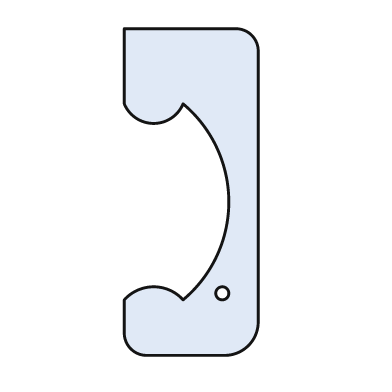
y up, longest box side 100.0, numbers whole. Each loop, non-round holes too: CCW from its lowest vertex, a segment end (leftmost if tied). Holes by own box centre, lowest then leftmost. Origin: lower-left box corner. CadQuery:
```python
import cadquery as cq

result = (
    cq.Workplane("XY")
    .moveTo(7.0, 0.0)
    .lineTo(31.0, 0.0)
    .threePointArc((38.0, 3.0), (41.0, 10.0))
    .lineTo(41.0, 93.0)
    .threePointArc((39.0, 98.0), (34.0, 100.0))
    .lineTo(0.0, 100.0)
    .lineTo(0.0, 77.0)
    .threePointArc((9.0, 71.0), (18.0, 77.0))
    .threePointArc((32.0, 47.0), (18.0, 17.0))
    .threePointArc((9.0, 21.0), (0.0, 17.0))
    .lineTo(0.0, 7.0)
    .threePointArc((2.0, 2.0), (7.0, 0.0))
    .close()
    .moveTo(30.0, 19.0)
    .circle(2.0)
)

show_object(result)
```